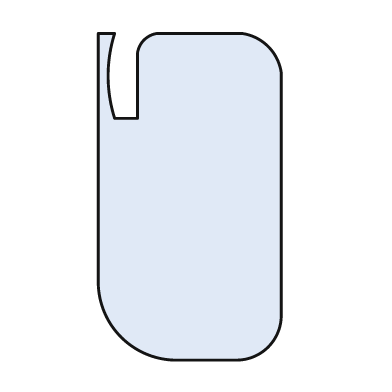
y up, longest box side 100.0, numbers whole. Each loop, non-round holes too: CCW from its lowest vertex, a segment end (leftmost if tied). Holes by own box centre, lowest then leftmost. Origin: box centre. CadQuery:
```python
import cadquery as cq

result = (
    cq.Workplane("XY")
    .moveTo(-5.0, -50.0)
    .lineTo(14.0, -50.0)
    .threePointArc((24.0, -46.0), (28.0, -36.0))
    .lineTo(28.0, 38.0)
    .threePointArc((24.0, 46.0), (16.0, 50.0))
    .lineTo(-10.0, 50.0)
    .threePointArc((-14.0, 48.0), (-16.0, 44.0))
    .lineTo(-16.0, 24.0)
    .lineTo(-23.0, 24.0)
    .threePointArc((-25.0, 37.0), (-23.0, 50.0))
    .lineTo(-28.0, 50.0)
    .lineTo(-28.0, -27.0)
    .threePointArc((-21.0, -43.0), (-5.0, -50.0))
    .close()
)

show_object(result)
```